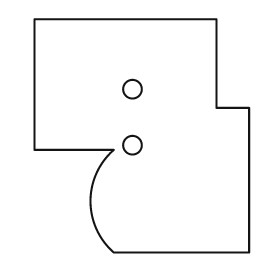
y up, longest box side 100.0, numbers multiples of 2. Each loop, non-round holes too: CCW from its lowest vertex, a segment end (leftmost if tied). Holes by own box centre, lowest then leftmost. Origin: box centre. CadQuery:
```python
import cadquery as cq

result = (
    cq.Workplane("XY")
    .moveTo(-12.0, -50.0)
    .lineTo(46.0, -50.0)
    .lineTo(46.0, 12.0)
    .lineTo(32.0, 12.0)
    .lineTo(32.0, 50.0)
    .lineTo(-46.0, 50.0)
    .lineTo(-46.0, -6.0)
    .lineTo(-12.0, -6.0)
    .threePointArc((-22.0, -28.0), (-12.0, -50.0))
    .close()
    .moveTo(-4.0, -4.0)
    .circle(4.0)
    .moveTo(-4.0, 20.0)
    .circle(4.0)
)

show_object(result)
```